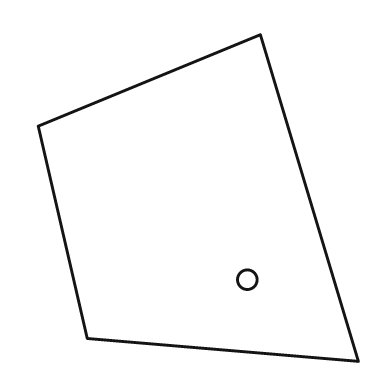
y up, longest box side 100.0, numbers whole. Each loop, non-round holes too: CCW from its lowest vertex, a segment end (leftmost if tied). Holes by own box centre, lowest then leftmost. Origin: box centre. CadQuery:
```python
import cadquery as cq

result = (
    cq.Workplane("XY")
    .moveTo(49.0, -50.0)
    .lineTo(19.0, 50.0)
    .lineTo(-49.0, 22.0)
    .lineTo(-34.0, -43.0)
    .close()
    .moveTo(15.0, -25.0)
    .circle(3.0)
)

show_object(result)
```